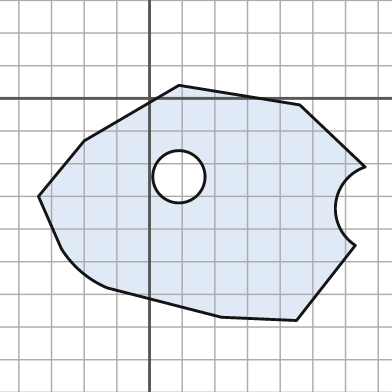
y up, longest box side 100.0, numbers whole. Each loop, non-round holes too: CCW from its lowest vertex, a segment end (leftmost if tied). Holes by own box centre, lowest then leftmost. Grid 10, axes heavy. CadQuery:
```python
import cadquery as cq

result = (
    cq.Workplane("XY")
    .moveTo(45.0, -68.0)
    .lineTo(63.0, -45.0)
    .threePointArc((57.0, -32.0), (66.0, -21.0))
    .lineTo(46.0, -2.0)
    .lineTo(9.0, 4.0)
    .lineTo(-20.0, -13.0)
    .lineTo(-34.0, -30.0)
    .lineTo(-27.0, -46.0)
    .threePointArc((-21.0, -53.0), (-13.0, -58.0))
    .lineTo(22.0, -67.0)
    .close()
    .moveTo(9.0, -24.0)
    .circle(8.0)
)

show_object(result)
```